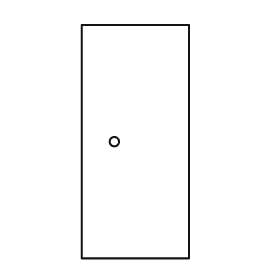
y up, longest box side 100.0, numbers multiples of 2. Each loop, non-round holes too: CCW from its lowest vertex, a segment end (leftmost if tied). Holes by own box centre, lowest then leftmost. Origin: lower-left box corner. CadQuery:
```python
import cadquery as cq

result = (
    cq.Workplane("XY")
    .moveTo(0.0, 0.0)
    .lineTo(46.0, 0.0)
    .lineTo(46.0, 100.0)
    .lineTo(0.0, 100.0)
    .close()
    .moveTo(14.0, 50.0)
    .circle(2.0)
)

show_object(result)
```